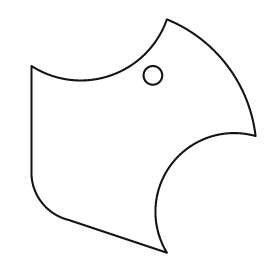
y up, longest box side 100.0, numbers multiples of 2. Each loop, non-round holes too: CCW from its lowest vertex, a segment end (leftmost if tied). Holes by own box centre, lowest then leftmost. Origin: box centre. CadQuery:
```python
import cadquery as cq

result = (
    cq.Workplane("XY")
    .moveTo(10.0, -50.0)
    .threePointArc((12.0, -12.0), (48.0, 0.0))
    .threePointArc((36.0, 30.0), (10.0, 50.0))
    .threePointArc((-14.0, 26.0), (-48.0, 30.0))
    .lineTo(-48.0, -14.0)
    .threePointArc((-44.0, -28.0), (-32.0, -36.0))
    .close()
    .moveTo(4.0, 26.0)
    .circle(4.0)
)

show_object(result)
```